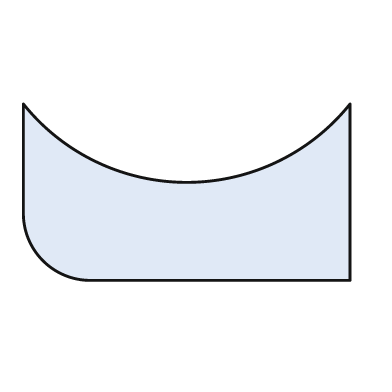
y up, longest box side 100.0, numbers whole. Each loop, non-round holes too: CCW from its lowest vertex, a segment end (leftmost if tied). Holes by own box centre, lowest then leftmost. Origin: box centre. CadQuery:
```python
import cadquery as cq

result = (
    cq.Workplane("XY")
    .moveTo(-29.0, -27.0)
    .lineTo(50.0, -27.0)
    .lineTo(50.0, 27.0)
    .threePointArc((0.0, 3.0), (-50.0, 27.0))
    .lineTo(-50.0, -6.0)
    .threePointArc((-44.0, -21.0), (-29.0, -27.0))
    .close()
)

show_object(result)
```